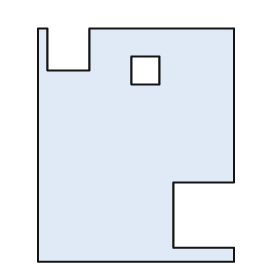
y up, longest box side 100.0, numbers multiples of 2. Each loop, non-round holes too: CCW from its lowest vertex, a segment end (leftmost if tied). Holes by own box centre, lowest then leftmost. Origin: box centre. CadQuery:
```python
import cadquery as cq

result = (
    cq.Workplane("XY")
    .moveTo(-42.0, -50.0)
    .lineTo(42.0, -50.0)
    .lineTo(42.0, -44.0)
    .lineTo(16.0, -44.0)
    .lineTo(16.0, -16.0)
    .lineTo(42.0, -16.0)
    .lineTo(42.0, 50.0)
    .lineTo(-20.0, 50.0)
    .lineTo(-20.0, 32.0)
    .lineTo(-38.0, 32.0)
    .lineTo(-38.0, 50.0)
    .lineTo(-42.0, 50.0)
    .close()
    .moveTo(-2.0, 26.0)
    .lineTo(10.0, 26.0)
    .lineTo(10.0, 38.0)
    .lineTo(-2.0, 38.0)
    .close()
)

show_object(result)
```